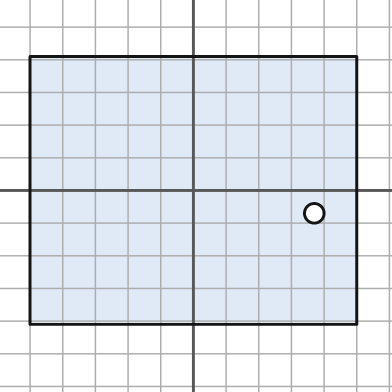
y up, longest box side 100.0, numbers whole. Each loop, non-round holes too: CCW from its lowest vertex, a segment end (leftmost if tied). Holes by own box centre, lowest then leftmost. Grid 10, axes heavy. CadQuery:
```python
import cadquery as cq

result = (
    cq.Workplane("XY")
    .moveTo(-50.0, -41.0)
    .lineTo(50.0, -41.0)
    .lineTo(50.0, 41.0)
    .lineTo(-50.0, 41.0)
    .close()
    .moveTo(37.0, -7.0)
    .circle(3.0)
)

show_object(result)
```